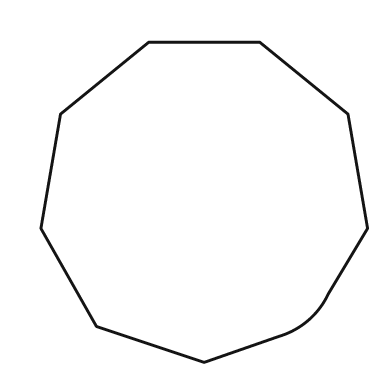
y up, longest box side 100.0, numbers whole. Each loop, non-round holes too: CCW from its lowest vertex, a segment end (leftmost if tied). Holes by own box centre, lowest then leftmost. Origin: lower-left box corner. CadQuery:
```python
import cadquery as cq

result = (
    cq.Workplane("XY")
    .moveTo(50.0, 0.0)
    .lineTo(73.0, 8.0)
    .threePointArc((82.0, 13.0), (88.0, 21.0))
    .lineTo(100.0, 41.0)
    .lineTo(94.0, 76.0)
    .lineTo(67.0, 98.0)
    .lineTo(33.0, 98.0)
    .lineTo(6.0, 76.0)
    .lineTo(0.0, 41.0)
    .lineTo(17.0, 11.0)
    .close()
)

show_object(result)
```